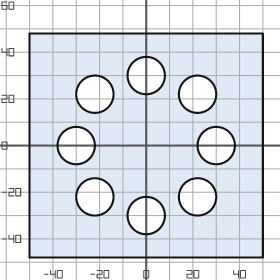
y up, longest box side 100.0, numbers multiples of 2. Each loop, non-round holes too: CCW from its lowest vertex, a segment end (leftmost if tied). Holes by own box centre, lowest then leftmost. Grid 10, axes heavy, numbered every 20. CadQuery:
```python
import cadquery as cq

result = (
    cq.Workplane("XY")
    .moveTo(-50.0, -48.0)
    .lineTo(50.0, -48.0)
    .lineTo(50.0, 48.0)
    .lineTo(-50.0, 48.0)
    .close()
    .moveTo(0.0, -30.0)
    .circle(8.0)
    .moveTo(-22.0, -22.0)
    .circle(8.0)
    .moveTo(22.0, -22.0)
    .circle(8.0)
    .moveTo(-30.0, 0.0)
    .circle(8.0)
    .moveTo(30.0, 0.0)
    .circle(8.0)
    .moveTo(-22.0, 22.0)
    .circle(8.0)
    .moveTo(22.0, 22.0)
    .circle(8.0)
    .moveTo(0.0, 30.0)
    .circle(8.0)
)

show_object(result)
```